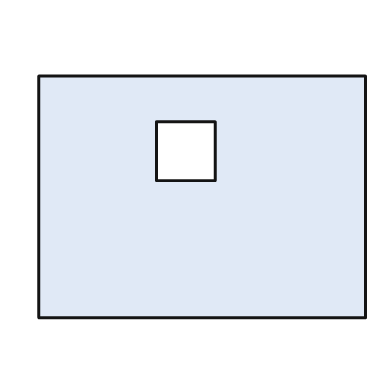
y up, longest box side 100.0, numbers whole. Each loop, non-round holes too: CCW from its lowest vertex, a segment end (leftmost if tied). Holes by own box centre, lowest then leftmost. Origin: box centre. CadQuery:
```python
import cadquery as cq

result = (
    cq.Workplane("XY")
    .moveTo(-50.0, -37.0)
    .lineTo(50.0, -37.0)
    .lineTo(50.0, 37.0)
    .lineTo(-50.0, 37.0)
    .close()
    .moveTo(-14.0, 5.0)
    .lineTo(4.0, 5.0)
    .lineTo(4.0, 23.0)
    .lineTo(-14.0, 23.0)
    .close()
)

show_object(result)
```